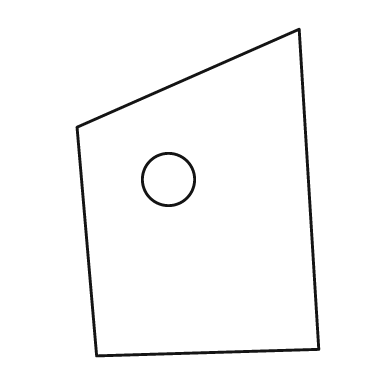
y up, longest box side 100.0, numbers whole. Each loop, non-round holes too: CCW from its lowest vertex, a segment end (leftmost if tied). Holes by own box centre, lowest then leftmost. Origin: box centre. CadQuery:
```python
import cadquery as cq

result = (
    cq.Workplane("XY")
    .moveTo(-31.0, -50.0)
    .lineTo(37.0, -48.0)
    .lineTo(31.0, 50.0)
    .lineTo(-37.0, 20.0)
    .close()
    .moveTo(-9.0, 4.0)
    .circle(8.0)
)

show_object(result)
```